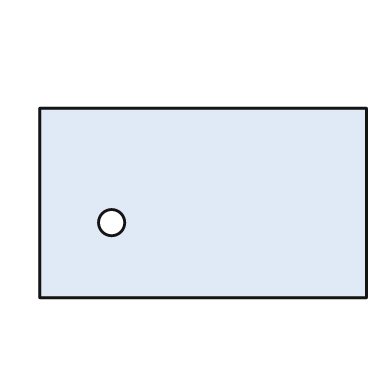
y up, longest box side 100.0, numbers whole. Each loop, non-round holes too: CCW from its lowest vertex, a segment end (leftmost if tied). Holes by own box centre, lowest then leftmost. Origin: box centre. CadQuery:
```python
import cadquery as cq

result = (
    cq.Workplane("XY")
    .moveTo(-50.0, -29.0)
    .lineTo(50.0, -29.0)
    .lineTo(50.0, 29.0)
    .lineTo(-50.0, 29.0)
    .close()
    .moveTo(-28.0, -6.0)
    .circle(4.0)
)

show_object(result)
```